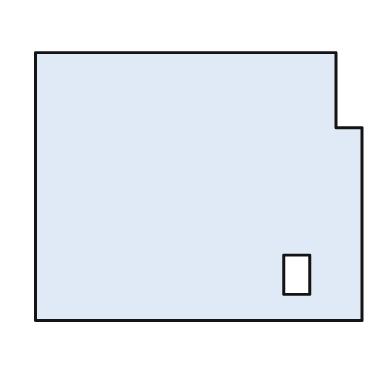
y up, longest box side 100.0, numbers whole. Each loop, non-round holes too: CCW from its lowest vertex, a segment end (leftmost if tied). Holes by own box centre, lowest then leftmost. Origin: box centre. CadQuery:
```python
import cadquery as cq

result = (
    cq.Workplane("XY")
    .moveTo(-50.0, -41.0)
    .lineTo(50.0, -41.0)
    .lineTo(50.0, 18.0)
    .lineTo(42.0, 18.0)
    .lineTo(42.0, 41.0)
    .lineTo(-50.0, 41.0)
    .close()
    .moveTo(26.0, -33.0)
    .lineTo(34.0, -33.0)
    .lineTo(34.0, -21.0)
    .lineTo(26.0, -21.0)
    .close()
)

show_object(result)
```